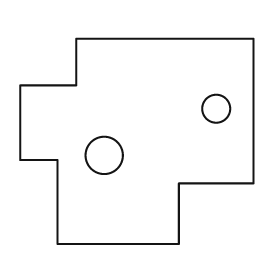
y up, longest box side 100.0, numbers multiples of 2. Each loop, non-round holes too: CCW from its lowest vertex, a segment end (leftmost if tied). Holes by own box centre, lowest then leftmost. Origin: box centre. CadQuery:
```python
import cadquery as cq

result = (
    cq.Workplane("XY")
    .moveTo(-34.0, -44.0)
    .lineTo(18.0, -44.0)
    .lineTo(18.0, -18.0)
    .lineTo(50.0, -18.0)
    .lineTo(50.0, 44.0)
    .lineTo(-26.0, 44.0)
    .lineTo(-26.0, 24.0)
    .lineTo(-50.0, 24.0)
    .lineTo(-50.0, -8.0)
    .lineTo(-34.0, -8.0)
    .close()
    .moveTo(-14.0, -6.0)
    .circle(8.0)
    .moveTo(34.0, 14.0)
    .circle(6.0)
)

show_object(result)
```